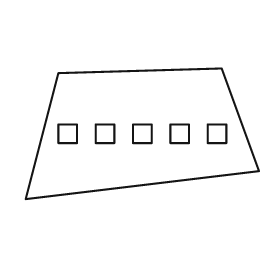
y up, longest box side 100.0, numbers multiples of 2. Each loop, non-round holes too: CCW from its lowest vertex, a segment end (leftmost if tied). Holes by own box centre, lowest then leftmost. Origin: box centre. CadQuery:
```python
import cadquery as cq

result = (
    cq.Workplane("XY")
    .moveTo(-50.0, -28.0)
    .lineTo(50.0, -16.0)
    .lineTo(34.0, 28.0)
    .lineTo(-36.0, 26.0)
    .close()
    .moveTo(-36.0, -4.0)
    .lineTo(-28.0, -4.0)
    .lineTo(-28.0, 4.0)
    .lineTo(-36.0, 4.0)
    .close()
    .moveTo(-20.0, -4.0)
    .lineTo(-12.0, -4.0)
    .lineTo(-12.0, 4.0)
    .lineTo(-20.0, 4.0)
    .close()
    .moveTo(-4.0, -4.0)
    .lineTo(4.0, -4.0)
    .lineTo(4.0, 4.0)
    .lineTo(-4.0, 4.0)
    .close()
    .moveTo(12.0, -4.0)
    .lineTo(20.0, -4.0)
    .lineTo(20.0, 4.0)
    .lineTo(12.0, 4.0)
    .close()
    .moveTo(28.0, -4.0)
    .lineTo(36.0, -4.0)
    .lineTo(36.0, 4.0)
    .lineTo(28.0, 4.0)
    .close()
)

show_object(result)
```